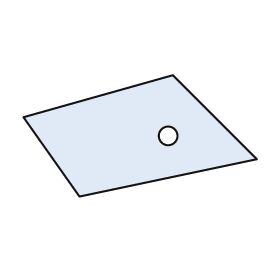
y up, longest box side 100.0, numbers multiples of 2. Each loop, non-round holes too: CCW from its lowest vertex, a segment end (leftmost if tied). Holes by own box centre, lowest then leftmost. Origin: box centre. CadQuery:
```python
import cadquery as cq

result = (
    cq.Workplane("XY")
    .moveTo(-26.0, -26.0)
    .lineTo(50.0, -10.0)
    .lineTo(14.0, 26.0)
    .lineTo(-50.0, 8.0)
    .close()
    .moveTo(12.0, 0.0)
    .circle(4.0)
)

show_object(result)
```